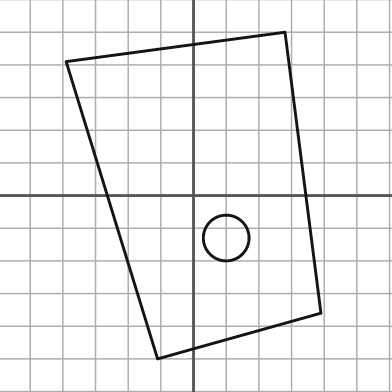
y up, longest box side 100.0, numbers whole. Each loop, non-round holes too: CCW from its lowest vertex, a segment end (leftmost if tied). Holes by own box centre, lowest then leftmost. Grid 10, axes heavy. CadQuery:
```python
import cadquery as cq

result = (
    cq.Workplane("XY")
    .moveTo(-11.0, -50.0)
    .lineTo(39.0, -36.0)
    .lineTo(28.0, 50.0)
    .lineTo(-39.0, 41.0)
    .close()
    .moveTo(10.0, -13.0)
    .circle(7.0)
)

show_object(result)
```